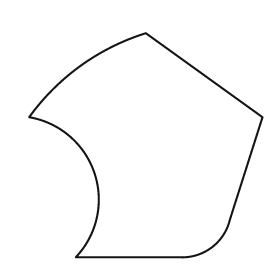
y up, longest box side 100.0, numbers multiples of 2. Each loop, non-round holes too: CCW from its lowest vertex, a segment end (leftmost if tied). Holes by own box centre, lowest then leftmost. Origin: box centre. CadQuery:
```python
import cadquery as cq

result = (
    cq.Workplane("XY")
    .moveTo(-30.0, -48.0)
    .lineTo(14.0, -48.0)
    .threePointArc((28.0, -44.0), (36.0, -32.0))
    .lineTo(50.0, 12.0)
    .lineTo(0.0, 48.0)
    .threePointArc((-28.0, 34.0), (-50.0, 12.0))
    .threePointArc((-22.0, -12.0), (-30.0, -48.0))
    .close()
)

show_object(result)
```